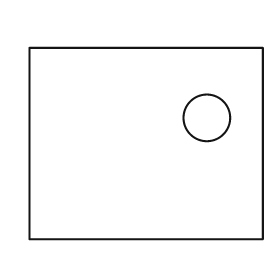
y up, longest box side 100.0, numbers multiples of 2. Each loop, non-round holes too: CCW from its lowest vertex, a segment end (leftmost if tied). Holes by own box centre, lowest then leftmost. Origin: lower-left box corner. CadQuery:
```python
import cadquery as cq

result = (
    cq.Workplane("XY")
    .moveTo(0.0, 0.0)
    .lineTo(100.0, 0.0)
    .lineTo(100.0, 82.0)
    .lineTo(0.0, 82.0)
    .close()
    .moveTo(76.0, 52.0)
    .circle(10.0)
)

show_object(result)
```